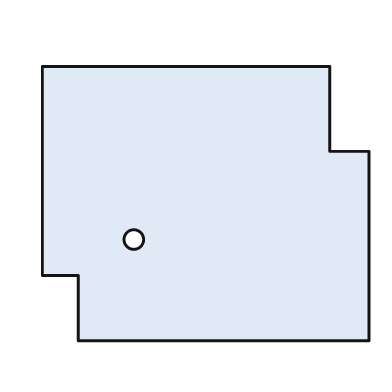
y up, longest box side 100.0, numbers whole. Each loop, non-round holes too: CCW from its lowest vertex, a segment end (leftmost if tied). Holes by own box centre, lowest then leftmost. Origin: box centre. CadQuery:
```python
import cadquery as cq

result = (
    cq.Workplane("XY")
    .moveTo(-39.0, -42.0)
    .lineTo(50.0, -42.0)
    .lineTo(50.0, 16.0)
    .lineTo(38.0, 16.0)
    .lineTo(38.0, 42.0)
    .lineTo(-50.0, 42.0)
    .lineTo(-50.0, -22.0)
    .lineTo(-39.0, -22.0)
    .close()
    .moveTo(-22.0, -11.0)
    .circle(3.0)
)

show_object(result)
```